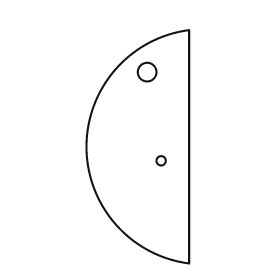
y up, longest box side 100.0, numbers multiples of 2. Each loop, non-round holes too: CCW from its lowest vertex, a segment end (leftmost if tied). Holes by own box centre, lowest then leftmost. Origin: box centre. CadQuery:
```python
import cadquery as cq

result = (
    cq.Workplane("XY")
    .moveTo(22.0, -50.0)
    .lineTo(22.0, 50.0)
    .threePointArc((-22.0, 0.0), (22.0, -50.0))
    .close()
    .moveTo(10.0, -6.0)
    .circle(2.0)
    .moveTo(4.0, 32.0)
    .circle(4.0)
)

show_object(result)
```